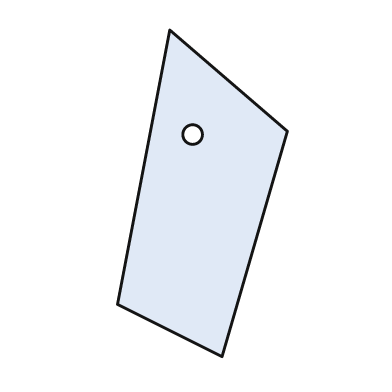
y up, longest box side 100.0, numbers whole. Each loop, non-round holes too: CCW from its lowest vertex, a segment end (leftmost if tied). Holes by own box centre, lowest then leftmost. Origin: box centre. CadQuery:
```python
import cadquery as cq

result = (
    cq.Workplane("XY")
    .moveTo(6.0, -50.0)
    .lineTo(26.0, 19.0)
    .lineTo(-10.0, 50.0)
    .lineTo(-26.0, -34.0)
    .close()
    .moveTo(-3.0, 18.0)
    .circle(3.0)
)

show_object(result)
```